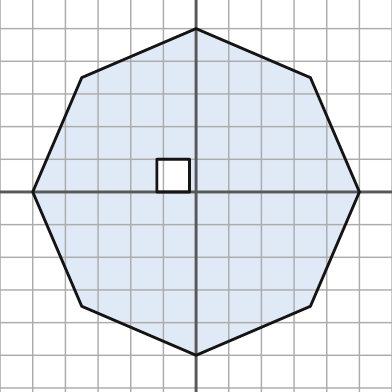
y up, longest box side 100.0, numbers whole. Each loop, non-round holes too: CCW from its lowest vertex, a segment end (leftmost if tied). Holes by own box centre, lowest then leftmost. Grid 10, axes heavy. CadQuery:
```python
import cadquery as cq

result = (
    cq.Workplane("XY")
    .moveTo(0.0, -50.0)
    .lineTo(35.0, -35.0)
    .lineTo(50.0, 0.0)
    .lineTo(35.0, 35.0)
    .lineTo(0.0, 50.0)
    .lineTo(-35.0, 35.0)
    .lineTo(-50.0, 0.0)
    .lineTo(-35.0, -35.0)
    .close()
    .moveTo(-12.0, 0.0)
    .lineTo(-2.0, 0.0)
    .lineTo(-2.0, 10.0)
    .lineTo(-12.0, 10.0)
    .close()
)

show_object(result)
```